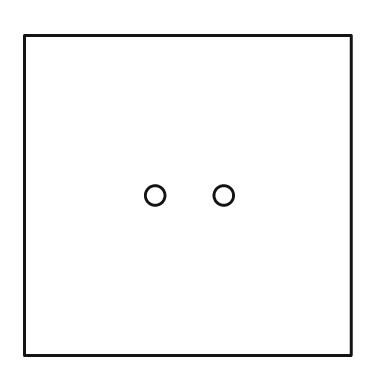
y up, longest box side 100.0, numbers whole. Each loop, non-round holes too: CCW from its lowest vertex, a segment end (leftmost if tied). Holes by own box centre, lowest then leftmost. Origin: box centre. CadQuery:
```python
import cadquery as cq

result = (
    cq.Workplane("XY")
    .moveTo(-50.0, -49.0)
    .lineTo(50.0, -49.0)
    .lineTo(50.0, 49.0)
    .lineTo(-50.0, 49.0)
    .close()
    .moveTo(-10.0, 0.0)
    .circle(3.0)
    .moveTo(11.0, 0.0)
    .circle(3.0)
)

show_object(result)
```